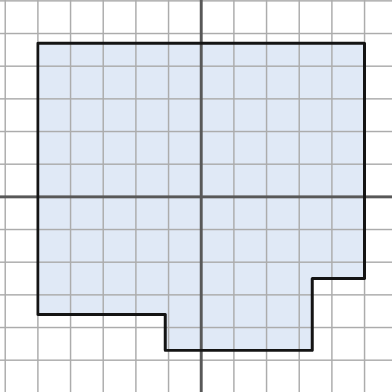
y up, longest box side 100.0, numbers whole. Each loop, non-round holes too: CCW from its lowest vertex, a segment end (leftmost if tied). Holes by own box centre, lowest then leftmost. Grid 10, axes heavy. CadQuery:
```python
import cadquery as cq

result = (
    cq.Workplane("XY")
    .moveTo(-11.0, -47.0)
    .lineTo(34.0, -47.0)
    .lineTo(34.0, -25.0)
    .lineTo(50.0, -25.0)
    .lineTo(50.0, 47.0)
    .lineTo(-50.0, 47.0)
    .lineTo(-50.0, -36.0)
    .lineTo(-11.0, -36.0)
    .close()
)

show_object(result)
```